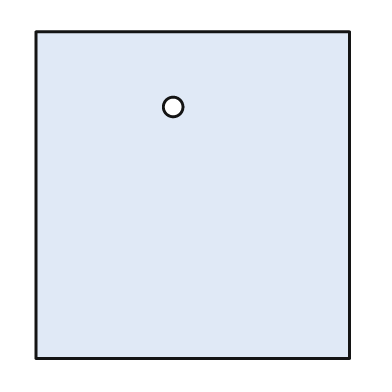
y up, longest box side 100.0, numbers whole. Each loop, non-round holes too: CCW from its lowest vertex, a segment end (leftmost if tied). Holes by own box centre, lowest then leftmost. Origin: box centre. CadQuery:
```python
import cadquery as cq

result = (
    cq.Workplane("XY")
    .moveTo(-48.0, -50.0)
    .lineTo(48.0, -50.0)
    .lineTo(48.0, 50.0)
    .lineTo(-48.0, 50.0)
    .close()
    .moveTo(-6.0, 27.0)
    .circle(3.0)
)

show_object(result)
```